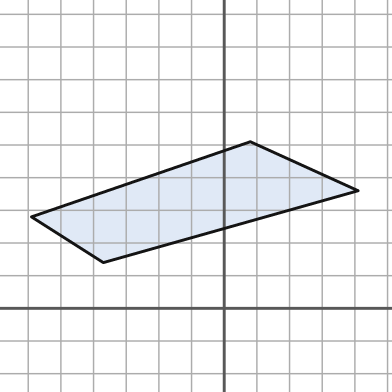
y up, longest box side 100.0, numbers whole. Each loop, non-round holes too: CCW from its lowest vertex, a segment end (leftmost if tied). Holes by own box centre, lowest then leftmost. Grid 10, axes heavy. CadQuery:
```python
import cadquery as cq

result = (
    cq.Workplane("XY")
    .moveTo(-37.0, 14.0)
    .lineTo(41.0, 36.0)
    .lineTo(8.0, 51.0)
    .lineTo(-59.0, 28.0)
    .close()
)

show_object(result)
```